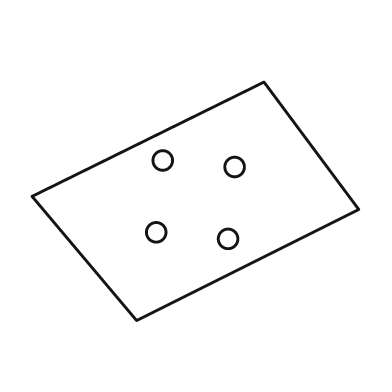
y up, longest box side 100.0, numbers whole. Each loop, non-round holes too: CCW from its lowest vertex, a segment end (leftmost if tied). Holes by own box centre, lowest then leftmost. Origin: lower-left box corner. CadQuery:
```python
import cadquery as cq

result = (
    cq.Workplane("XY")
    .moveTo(32.0, 0.0)
    .lineTo(100.0, 34.0)
    .lineTo(71.0, 73.0)
    .lineTo(0.0, 38.0)
    .close()
    .moveTo(60.0, 25.0)
    .circle(3.0)
    .moveTo(38.0, 27.0)
    .circle(3.0)
    .moveTo(62.0, 47.0)
    .circle(3.0)
    .moveTo(40.0, 49.0)
    .circle(3.0)
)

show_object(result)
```